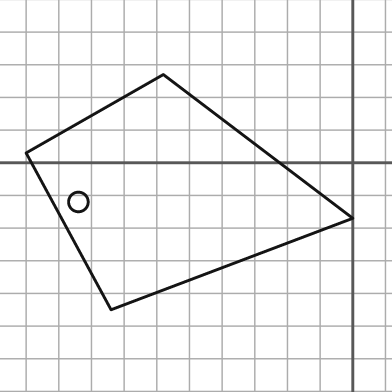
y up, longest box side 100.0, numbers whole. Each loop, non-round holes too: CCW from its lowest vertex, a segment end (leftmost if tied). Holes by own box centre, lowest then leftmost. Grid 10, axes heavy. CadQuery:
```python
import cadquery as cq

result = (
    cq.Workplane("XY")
    .moveTo(-74.0, -45.0)
    .lineTo(0.0, -17.0)
    .lineTo(-58.0, 27.0)
    .lineTo(-100.0, 3.0)
    .close()
    .moveTo(-84.0, -12.0)
    .circle(3.0)
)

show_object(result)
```